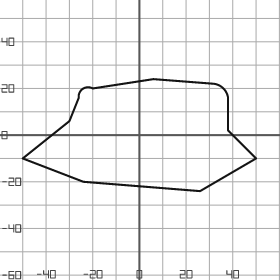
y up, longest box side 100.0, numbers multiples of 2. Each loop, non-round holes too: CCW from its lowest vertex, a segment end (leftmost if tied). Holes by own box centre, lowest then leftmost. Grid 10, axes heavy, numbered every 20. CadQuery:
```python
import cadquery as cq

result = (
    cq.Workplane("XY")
    .moveTo(26.0, -24.0)
    .lineTo(50.0, -10.0)
    .lineTo(38.0, 2.0)
    .lineTo(38.0, 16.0)
    .threePointArc((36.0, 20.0), (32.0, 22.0))
    .lineTo(6.0, 24.0)
    .lineTo(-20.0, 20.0)
    .threePointArc((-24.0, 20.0), (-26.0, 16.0))
    .lineTo(-30.0, 6.0)
    .lineTo(-50.0, -10.0)
    .lineTo(-24.0, -20.0)
    .close()
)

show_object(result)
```